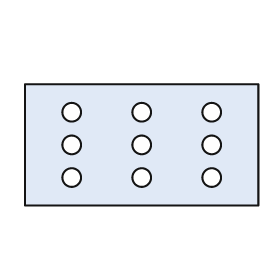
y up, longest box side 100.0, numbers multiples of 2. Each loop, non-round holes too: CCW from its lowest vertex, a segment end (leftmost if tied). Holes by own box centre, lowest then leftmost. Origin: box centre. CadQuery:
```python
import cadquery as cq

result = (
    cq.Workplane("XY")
    .moveTo(-50.0, -26.0)
    .lineTo(50.0, -26.0)
    .lineTo(50.0, 26.0)
    .lineTo(-50.0, 26.0)
    .close()
    .moveTo(-30.0, -14.0)
    .circle(4.0)
    .moveTo(0.0, -14.0)
    .circle(4.0)
    .moveTo(30.0, -14.0)
    .circle(4.0)
    .moveTo(-30.0, 0.0)
    .circle(4.0)
    .moveTo(0.0, 0.0)
    .circle(4.0)
    .moveTo(30.0, 0.0)
    .circle(4.0)
    .moveTo(-30.0, 14.0)
    .circle(4.0)
    .moveTo(0.0, 14.0)
    .circle(4.0)
    .moveTo(30.0, 14.0)
    .circle(4.0)
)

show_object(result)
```